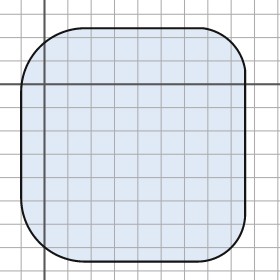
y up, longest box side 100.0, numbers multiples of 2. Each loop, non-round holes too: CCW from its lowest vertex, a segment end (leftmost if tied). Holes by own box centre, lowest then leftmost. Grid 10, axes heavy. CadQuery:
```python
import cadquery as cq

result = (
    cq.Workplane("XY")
    .moveTo(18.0, -76.0)
    .lineTo(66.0, -76.0)
    .threePointArc((80.0, -70.0), (86.0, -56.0))
    .lineTo(86.0, 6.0)
    .threePointArc((80.0, 18.0), (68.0, 24.0))
    .lineTo(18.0, 24.0)
    .threePointArc((-2.0, 16.0), (-10.0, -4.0))
    .lineTo(-10.0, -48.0)
    .threePointArc((-2.0, -68.0), (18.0, -76.0))
    .close()
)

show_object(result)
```